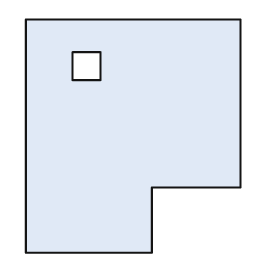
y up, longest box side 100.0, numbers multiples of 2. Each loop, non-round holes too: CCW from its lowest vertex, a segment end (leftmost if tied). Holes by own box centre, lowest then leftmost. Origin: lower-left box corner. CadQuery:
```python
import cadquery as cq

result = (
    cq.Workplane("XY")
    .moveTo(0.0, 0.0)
    .lineTo(54.0, 0.0)
    .lineTo(54.0, 28.0)
    .lineTo(92.0, 28.0)
    .lineTo(92.0, 100.0)
    .lineTo(0.0, 100.0)
    .close()
    .moveTo(20.0, 74.0)
    .lineTo(32.0, 74.0)
    .lineTo(32.0, 86.0)
    .lineTo(20.0, 86.0)
    .close()
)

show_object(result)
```